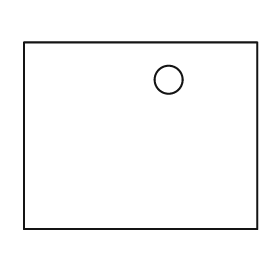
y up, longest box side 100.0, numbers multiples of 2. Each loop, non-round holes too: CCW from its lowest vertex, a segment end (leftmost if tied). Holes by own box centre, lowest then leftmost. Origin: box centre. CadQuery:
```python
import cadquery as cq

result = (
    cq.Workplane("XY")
    .moveTo(-50.0, -40.0)
    .lineTo(50.0, -40.0)
    .lineTo(50.0, 40.0)
    .lineTo(-50.0, 40.0)
    .close()
    .moveTo(12.0, 24.0)
    .circle(6.0)
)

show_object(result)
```